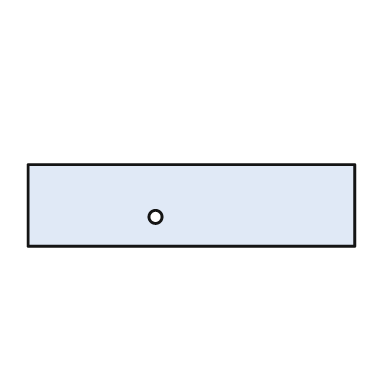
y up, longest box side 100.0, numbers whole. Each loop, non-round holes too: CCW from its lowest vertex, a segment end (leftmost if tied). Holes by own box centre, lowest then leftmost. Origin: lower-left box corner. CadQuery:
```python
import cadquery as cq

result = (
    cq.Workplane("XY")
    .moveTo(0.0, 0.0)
    .lineTo(100.0, 0.0)
    .lineTo(100.0, 25.0)
    .lineTo(0.0, 25.0)
    .close()
    .moveTo(39.0, 9.0)
    .circle(2.0)
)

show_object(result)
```